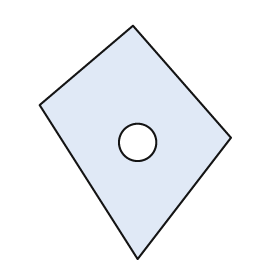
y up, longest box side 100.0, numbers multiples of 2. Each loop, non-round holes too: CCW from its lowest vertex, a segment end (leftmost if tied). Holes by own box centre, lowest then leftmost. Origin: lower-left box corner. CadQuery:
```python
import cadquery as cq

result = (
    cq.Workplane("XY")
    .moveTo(42.0, 0.0)
    .lineTo(82.0, 52.0)
    .lineTo(40.0, 100.0)
    .lineTo(0.0, 66.0)
    .close()
    .moveTo(42.0, 50.0)
    .circle(8.0)
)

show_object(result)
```